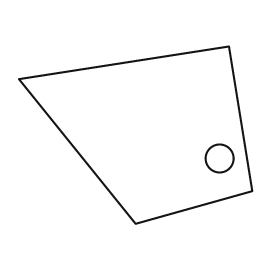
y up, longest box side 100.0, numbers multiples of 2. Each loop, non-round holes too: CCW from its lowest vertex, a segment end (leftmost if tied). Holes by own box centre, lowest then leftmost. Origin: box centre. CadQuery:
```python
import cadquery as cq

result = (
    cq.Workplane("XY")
    .moveTo(0.0, -38.0)
    .lineTo(50.0, -24.0)
    .lineTo(40.0, 38.0)
    .lineTo(-50.0, 24.0)
    .close()
    .moveTo(36.0, -10.0)
    .circle(6.0)
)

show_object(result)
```